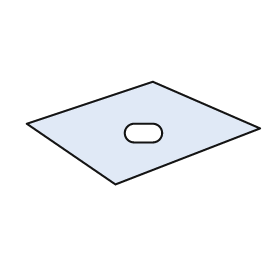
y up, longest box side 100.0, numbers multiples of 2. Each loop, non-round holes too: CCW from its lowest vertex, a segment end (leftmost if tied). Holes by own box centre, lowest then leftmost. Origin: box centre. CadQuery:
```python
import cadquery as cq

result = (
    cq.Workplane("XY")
    .moveTo(-12.0, -22.0)
    .lineTo(50.0, 2.0)
    .lineTo(4.0, 22.0)
    .lineTo(-50.0, 4.0)
    .close()
    .moveTo(-4.0, -4.0)
    .lineTo(4.0, -4.0)
    .threePointArc((8.0, 0.0), (4.0, 4.0))
    .lineTo(-4.0, 4.0)
    .threePointArc((-8.0, 0.0), (-4.0, -4.0))
    .close()
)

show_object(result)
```